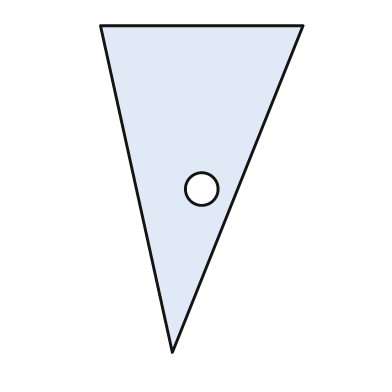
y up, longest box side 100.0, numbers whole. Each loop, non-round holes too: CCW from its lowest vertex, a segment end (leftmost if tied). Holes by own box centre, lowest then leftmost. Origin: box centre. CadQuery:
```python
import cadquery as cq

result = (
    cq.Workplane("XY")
    .moveTo(-9.0, -50.0)
    .lineTo(31.0, 50.0)
    .lineTo(-31.0, 50.0)
    .close()
    .moveTo(0.0, 0.0)
    .circle(5.0)
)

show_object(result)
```